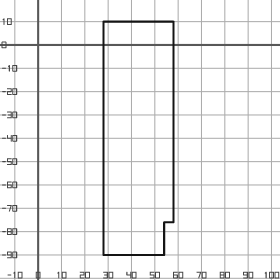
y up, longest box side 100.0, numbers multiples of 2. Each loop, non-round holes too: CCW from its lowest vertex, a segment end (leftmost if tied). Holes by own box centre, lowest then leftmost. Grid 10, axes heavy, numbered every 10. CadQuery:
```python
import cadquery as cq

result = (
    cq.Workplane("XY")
    .moveTo(28.0, -90.0)
    .lineTo(54.0, -90.0)
    .lineTo(54.0, -76.0)
    .lineTo(58.0, -76.0)
    .lineTo(58.0, 10.0)
    .lineTo(28.0, 10.0)
    .close()
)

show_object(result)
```